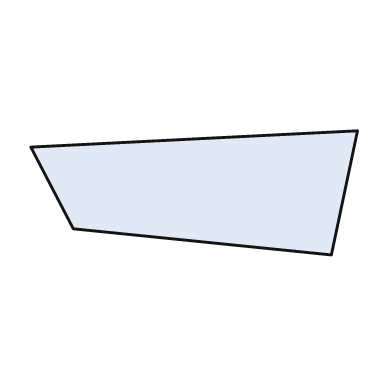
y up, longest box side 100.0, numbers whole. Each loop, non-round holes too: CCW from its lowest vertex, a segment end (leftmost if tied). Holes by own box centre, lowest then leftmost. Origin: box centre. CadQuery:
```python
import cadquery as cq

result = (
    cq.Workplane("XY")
    .moveTo(42.0, -19.0)
    .lineTo(50.0, 19.0)
    .lineTo(-50.0, 14.0)
    .lineTo(-37.0, -11.0)
    .close()
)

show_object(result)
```